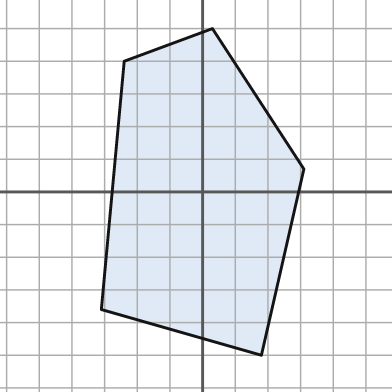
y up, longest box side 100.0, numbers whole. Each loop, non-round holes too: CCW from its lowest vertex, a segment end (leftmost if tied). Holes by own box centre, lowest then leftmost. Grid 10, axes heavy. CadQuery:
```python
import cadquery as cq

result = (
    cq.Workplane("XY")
    .moveTo(18.0, -50.0)
    .lineTo(31.0, 7.0)
    .lineTo(3.0, 50.0)
    .lineTo(-24.0, 40.0)
    .lineTo(-31.0, -36.0)
    .close()
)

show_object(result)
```